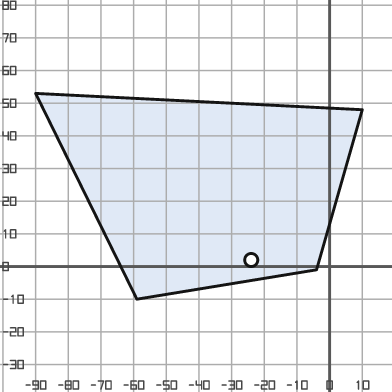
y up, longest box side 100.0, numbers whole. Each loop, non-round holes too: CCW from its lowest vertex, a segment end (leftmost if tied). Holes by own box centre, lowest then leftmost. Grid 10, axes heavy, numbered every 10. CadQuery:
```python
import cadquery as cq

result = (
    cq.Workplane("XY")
    .moveTo(-59.0, -10.0)
    .lineTo(-4.0, -1.0)
    .lineTo(10.0, 48.0)
    .lineTo(-90.0, 53.0)
    .close()
    .moveTo(-24.0, 2.0)
    .circle(2.0)
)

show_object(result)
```